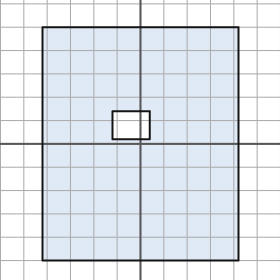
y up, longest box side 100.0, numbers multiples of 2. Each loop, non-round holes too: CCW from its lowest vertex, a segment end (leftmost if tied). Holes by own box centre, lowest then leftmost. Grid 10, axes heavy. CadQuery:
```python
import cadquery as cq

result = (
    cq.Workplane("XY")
    .moveTo(-42.0, -50.0)
    .lineTo(42.0, -50.0)
    .lineTo(42.0, 50.0)
    .lineTo(-42.0, 50.0)
    .close()
    .moveTo(-12.0, 2.0)
    .lineTo(4.0, 2.0)
    .lineTo(4.0, 14.0)
    .lineTo(-12.0, 14.0)
    .close()
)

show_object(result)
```